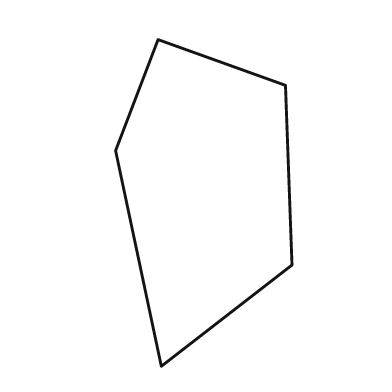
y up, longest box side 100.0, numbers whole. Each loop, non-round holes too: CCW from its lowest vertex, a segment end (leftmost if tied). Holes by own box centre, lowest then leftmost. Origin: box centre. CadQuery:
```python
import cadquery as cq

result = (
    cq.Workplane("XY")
    .moveTo(-13.0, -50.0)
    .lineTo(27.0, -19.0)
    .lineTo(25.0, 36.0)
    .lineTo(-14.0, 50.0)
    .lineTo(-27.0, 16.0)
    .close()
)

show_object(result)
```